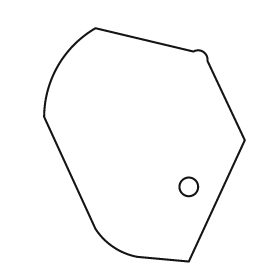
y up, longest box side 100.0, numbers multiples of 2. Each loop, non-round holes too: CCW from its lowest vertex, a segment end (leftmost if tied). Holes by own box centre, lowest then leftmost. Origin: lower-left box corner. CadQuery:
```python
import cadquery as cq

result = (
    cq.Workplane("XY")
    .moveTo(62.0, 0.0)
    .lineTo(86.0, 52.0)
    .lineTo(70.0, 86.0)
    .threePointArc((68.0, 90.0), (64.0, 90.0))
    .lineTo(22.0, 100.0)
    .threePointArc((6.0, 84.0), (0.0, 62.0))
    .lineTo(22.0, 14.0)
    .threePointArc((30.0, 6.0), (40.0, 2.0))
    .close()
    .moveTo(62.0, 32.0)
    .circle(4.0)
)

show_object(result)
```